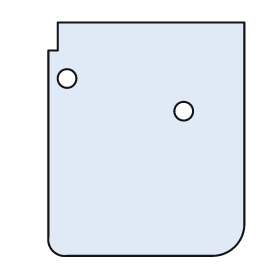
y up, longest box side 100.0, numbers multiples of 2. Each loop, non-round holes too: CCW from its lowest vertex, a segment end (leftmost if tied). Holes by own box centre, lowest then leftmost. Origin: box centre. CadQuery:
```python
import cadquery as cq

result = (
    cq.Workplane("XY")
    .moveTo(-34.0, -50.0)
    .lineTo(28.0, -50.0)
    .threePointArc((38.0, -46.0), (42.0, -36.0))
    .lineTo(42.0, 50.0)
    .lineTo(-38.0, 50.0)
    .lineTo(-38.0, 38.0)
    .lineTo(-42.0, 38.0)
    .lineTo(-42.0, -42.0)
    .threePointArc((-40.0, -48.0), (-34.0, -50.0))
    .close()
    .moveTo(16.0, 12.0)
    .circle(4.0)
    .moveTo(-34.0, 26.0)
    .circle(4.0)
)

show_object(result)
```